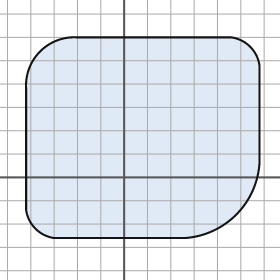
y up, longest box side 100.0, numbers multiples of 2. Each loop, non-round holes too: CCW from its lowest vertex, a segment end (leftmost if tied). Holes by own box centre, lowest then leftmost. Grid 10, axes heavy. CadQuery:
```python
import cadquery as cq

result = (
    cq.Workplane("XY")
    .moveTo(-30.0, -26.0)
    .lineTo(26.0, -26.0)
    .threePointArc((48.0, -16.0), (58.0, 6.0))
    .lineTo(58.0, 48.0)
    .threePointArc((54.0, 56.0), (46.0, 60.0))
    .lineTo(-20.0, 60.0)
    .threePointArc((-36.0, 54.0), (-42.0, 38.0))
    .lineTo(-42.0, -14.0)
    .threePointArc((-38.0, -22.0), (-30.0, -26.0))
    .close()
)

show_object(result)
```